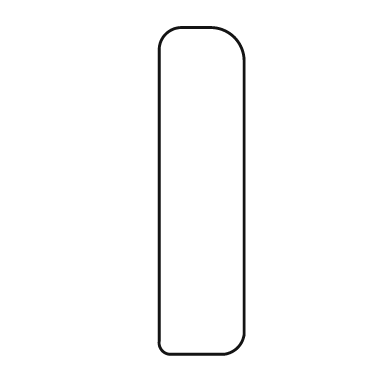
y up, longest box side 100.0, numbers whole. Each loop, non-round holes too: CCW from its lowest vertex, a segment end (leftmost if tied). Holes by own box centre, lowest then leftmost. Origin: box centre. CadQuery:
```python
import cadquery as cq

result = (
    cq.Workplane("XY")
    .moveTo(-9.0, -50.0)
    .lineTo(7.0, -50.0)
    .threePointArc((11.0, -48.0), (13.0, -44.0))
    .lineTo(13.0, 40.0)
    .threePointArc((10.0, 47.0), (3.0, 50.0))
    .lineTo(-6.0, 50.0)
    .threePointArc((-11.0, 48.0), (-13.0, 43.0))
    .lineTo(-13.0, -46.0)
    .threePointArc((-12.0, -49.0), (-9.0, -50.0))
    .close()
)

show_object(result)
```